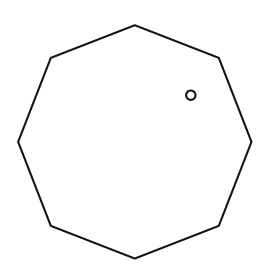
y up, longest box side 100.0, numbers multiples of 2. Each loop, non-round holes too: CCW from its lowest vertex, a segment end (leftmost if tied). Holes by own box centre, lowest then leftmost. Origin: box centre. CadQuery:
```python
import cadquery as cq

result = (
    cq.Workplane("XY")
    .moveTo(0.0, -50.0)
    .lineTo(36.0, -36.0)
    .lineTo(50.0, 0.0)
    .lineTo(36.0, 36.0)
    .lineTo(0.0, 50.0)
    .lineTo(-36.0, 36.0)
    .lineTo(-50.0, 0.0)
    .lineTo(-36.0, -36.0)
    .close()
    .moveTo(24.0, 20.0)
    .circle(2.0)
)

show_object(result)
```